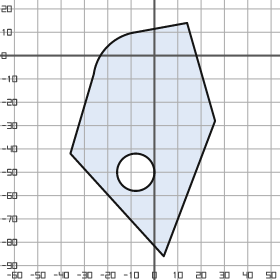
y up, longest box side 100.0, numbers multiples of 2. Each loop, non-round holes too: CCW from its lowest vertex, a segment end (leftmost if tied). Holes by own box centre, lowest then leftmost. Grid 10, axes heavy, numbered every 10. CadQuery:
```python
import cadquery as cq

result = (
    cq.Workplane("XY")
    .moveTo(4.0, -86.0)
    .lineTo(26.0, -28.0)
    .lineTo(14.0, 14.0)
    .lineTo(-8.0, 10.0)
    .threePointArc((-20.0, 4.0), (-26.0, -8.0))
    .lineTo(-36.0, -42.0)
    .close()
    .moveTo(-8.0, -50.0)
    .circle(8.0)
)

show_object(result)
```